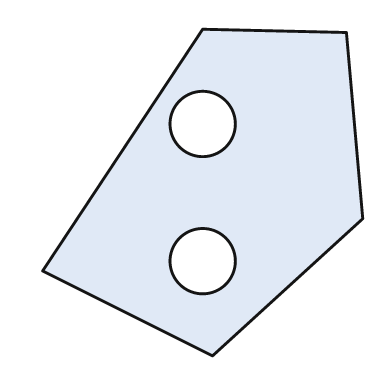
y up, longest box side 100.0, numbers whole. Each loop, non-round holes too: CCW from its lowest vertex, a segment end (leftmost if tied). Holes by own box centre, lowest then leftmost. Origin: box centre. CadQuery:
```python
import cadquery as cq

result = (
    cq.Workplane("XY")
    .moveTo(3.0, -50.0)
    .lineTo(49.0, -8.0)
    .lineTo(44.0, 49.0)
    .lineTo(0.0, 50.0)
    .lineTo(-49.0, -24.0)
    .close()
    .moveTo(0.0, -21.0)
    .circle(10.0)
    .moveTo(0.0, 21.0)
    .circle(10.0)
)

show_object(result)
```